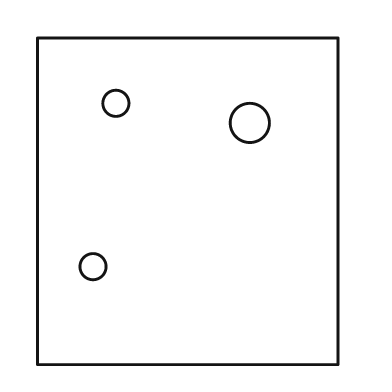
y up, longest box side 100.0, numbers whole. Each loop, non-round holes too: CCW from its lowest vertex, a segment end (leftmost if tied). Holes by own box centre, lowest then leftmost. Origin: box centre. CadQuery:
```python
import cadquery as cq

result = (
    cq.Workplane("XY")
    .moveTo(-46.0, -50.0)
    .lineTo(46.0, -50.0)
    .lineTo(46.0, 50.0)
    .lineTo(-46.0, 50.0)
    .close()
    .moveTo(-29.0, -20.0)
    .circle(4.0)
    .moveTo(19.0, 24.0)
    .circle(6.0)
    .moveTo(-22.0, 30.0)
    .circle(4.0)
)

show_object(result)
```